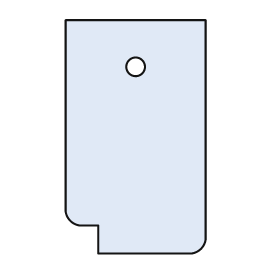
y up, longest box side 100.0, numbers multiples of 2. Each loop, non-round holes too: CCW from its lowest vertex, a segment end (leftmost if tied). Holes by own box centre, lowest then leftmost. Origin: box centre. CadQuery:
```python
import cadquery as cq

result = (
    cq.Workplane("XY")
    .moveTo(-16.0, -50.0)
    .lineTo(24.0, -50.0)
    .threePointArc((28.0, -48.0), (30.0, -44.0))
    .lineTo(30.0, 50.0)
    .lineTo(-30.0, 50.0)
    .lineTo(-30.0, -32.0)
    .threePointArc((-28.0, -36.0), (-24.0, -38.0))
    .lineTo(-16.0, -38.0)
    .close()
    .moveTo(0.0, 30.0)
    .circle(4.0)
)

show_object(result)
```